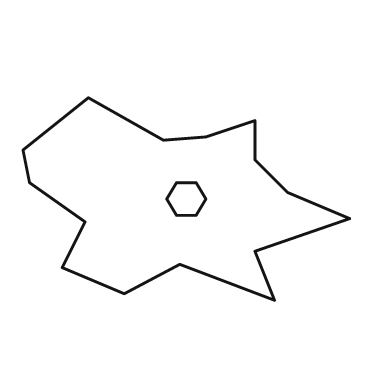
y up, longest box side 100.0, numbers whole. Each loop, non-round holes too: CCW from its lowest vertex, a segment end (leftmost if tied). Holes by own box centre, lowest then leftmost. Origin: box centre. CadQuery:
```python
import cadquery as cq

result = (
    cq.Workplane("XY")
    .moveTo(27.0, -31.0)
    .lineTo(21.0, -16.0)
    .lineTo(50.0, -6.0)
    .lineTo(31.0, 2.0)
    .lineTo(21.0, 12.0)
    .lineTo(21.0, 24.0)
    .lineTo(6.0, 19.0)
    .lineTo(-7.0, 18.0)
    .lineTo(-30.0, 31.0)
    .lineTo(-50.0, 15.0)
    .lineTo(-48.0, 5.0)
    .lineTo(-31.0, -7.0)
    .lineTo(-38.0, -21.0)
    .lineTo(-19.0, -29.0)
    .lineTo(-2.0, -20.0)
    .close()
    .moveTo(-3.0, -5.0)
    .lineTo(3.0, -5.0)
    .lineTo(6.0, 0.0)
    .lineTo(3.0, 5.0)
    .lineTo(-3.0, 5.0)
    .lineTo(-6.0, 0.0)
    .close()
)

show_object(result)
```